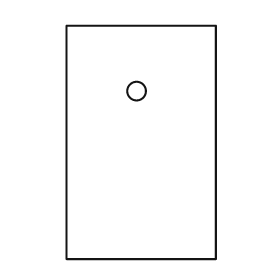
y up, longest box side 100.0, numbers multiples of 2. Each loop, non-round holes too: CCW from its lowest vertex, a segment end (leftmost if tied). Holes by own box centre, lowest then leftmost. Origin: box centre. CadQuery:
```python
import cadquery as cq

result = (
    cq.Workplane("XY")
    .moveTo(-32.0, -50.0)
    .lineTo(32.0, -50.0)
    .lineTo(32.0, 50.0)
    .lineTo(-32.0, 50.0)
    .close()
    .moveTo(-2.0, 22.0)
    .circle(4.0)
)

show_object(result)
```